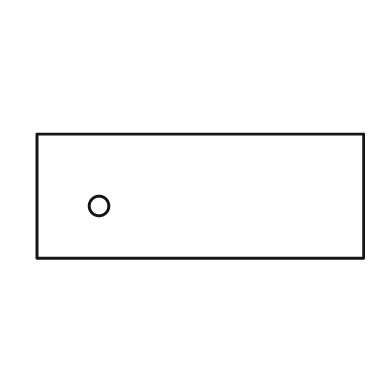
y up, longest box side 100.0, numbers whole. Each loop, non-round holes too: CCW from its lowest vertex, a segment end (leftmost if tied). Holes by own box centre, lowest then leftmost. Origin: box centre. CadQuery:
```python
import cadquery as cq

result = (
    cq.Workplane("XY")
    .moveTo(-50.0, -19.0)
    .lineTo(50.0, -19.0)
    .lineTo(50.0, 19.0)
    .lineTo(-50.0, 19.0)
    .close()
    .moveTo(-31.0, -3.0)
    .circle(3.0)
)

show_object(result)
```